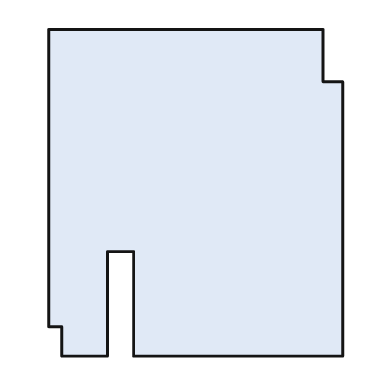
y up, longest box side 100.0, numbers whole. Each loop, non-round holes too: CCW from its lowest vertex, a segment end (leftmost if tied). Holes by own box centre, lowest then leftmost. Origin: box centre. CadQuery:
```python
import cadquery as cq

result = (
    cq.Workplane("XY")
    .moveTo(-41.0, -50.0)
    .lineTo(-27.0, -50.0)
    .lineTo(-27.0, -18.0)
    .lineTo(-19.0, -18.0)
    .lineTo(-19.0, -50.0)
    .lineTo(45.0, -50.0)
    .lineTo(45.0, 34.0)
    .lineTo(39.0, 34.0)
    .lineTo(39.0, 50.0)
    .lineTo(-45.0, 50.0)
    .lineTo(-45.0, -41.0)
    .lineTo(-41.0, -41.0)
    .close()
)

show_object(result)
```